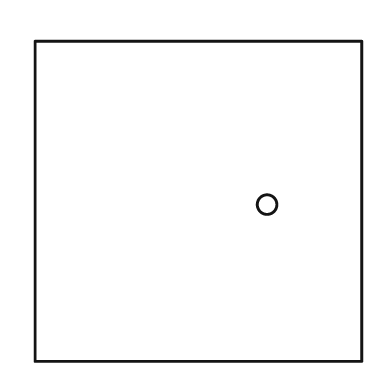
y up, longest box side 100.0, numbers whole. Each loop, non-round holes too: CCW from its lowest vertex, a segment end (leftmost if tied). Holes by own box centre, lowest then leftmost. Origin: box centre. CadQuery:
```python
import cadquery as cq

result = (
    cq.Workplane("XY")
    .moveTo(-50.0, -49.0)
    .lineTo(50.0, -49.0)
    .lineTo(50.0, 49.0)
    .lineTo(-50.0, 49.0)
    .close()
    .moveTo(21.0, -1.0)
    .circle(3.0)
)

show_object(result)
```